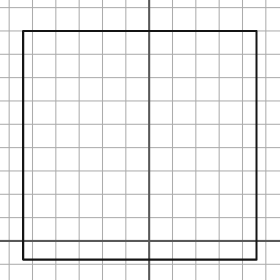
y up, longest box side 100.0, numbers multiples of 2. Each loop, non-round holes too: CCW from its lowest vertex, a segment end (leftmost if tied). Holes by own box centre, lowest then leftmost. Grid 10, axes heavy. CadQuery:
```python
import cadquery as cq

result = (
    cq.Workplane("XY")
    .moveTo(-54.0, -8.0)
    .lineTo(46.0, -8.0)
    .lineTo(46.0, 90.0)
    .lineTo(-54.0, 90.0)
    .close()
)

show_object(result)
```